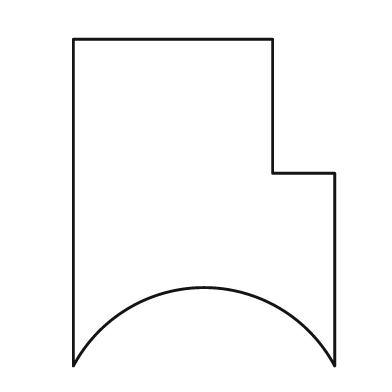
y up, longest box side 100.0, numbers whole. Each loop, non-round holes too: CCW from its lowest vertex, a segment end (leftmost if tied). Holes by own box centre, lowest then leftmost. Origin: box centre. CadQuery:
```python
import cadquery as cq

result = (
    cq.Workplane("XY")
    .moveTo(-40.0, -50.0)
    .threePointArc((0.0, -26.0), (40.0, -50.0))
    .lineTo(40.0, 9.0)
    .lineTo(21.0, 9.0)
    .lineTo(21.0, 50.0)
    .lineTo(-40.0, 50.0)
    .close()
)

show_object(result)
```